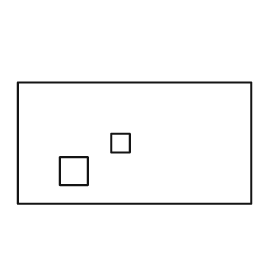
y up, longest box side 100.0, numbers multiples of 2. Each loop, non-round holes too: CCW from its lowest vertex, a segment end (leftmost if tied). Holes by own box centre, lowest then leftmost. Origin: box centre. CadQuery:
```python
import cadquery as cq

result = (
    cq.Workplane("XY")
    .moveTo(-50.0, -26.0)
    .lineTo(50.0, -26.0)
    .lineTo(50.0, 26.0)
    .lineTo(-50.0, 26.0)
    .close()
    .moveTo(-32.0, -18.0)
    .lineTo(-20.0, -18.0)
    .lineTo(-20.0, -6.0)
    .lineTo(-32.0, -6.0)
    .close()
    .moveTo(-10.0, -4.0)
    .lineTo(-2.0, -4.0)
    .lineTo(-2.0, 4.0)
    .lineTo(-10.0, 4.0)
    .close()
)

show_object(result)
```